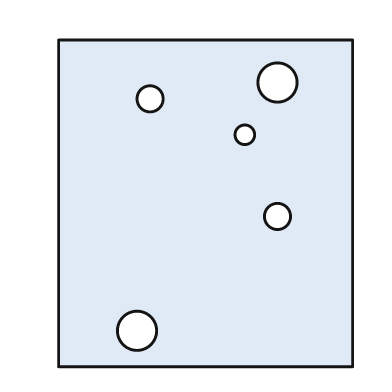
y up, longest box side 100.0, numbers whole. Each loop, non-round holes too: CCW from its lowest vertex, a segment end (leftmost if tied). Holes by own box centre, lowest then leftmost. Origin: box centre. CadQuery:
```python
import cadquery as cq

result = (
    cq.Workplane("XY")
    .moveTo(-45.0, -50.0)
    .lineTo(45.0, -50.0)
    .lineTo(45.0, 50.0)
    .lineTo(-45.0, 50.0)
    .close()
    .moveTo(-21.0, -39.0)
    .circle(6.0)
    .moveTo(22.0, -4.0)
    .circle(4.0)
    .moveTo(12.0, 21.0)
    .circle(3.0)
    .moveTo(-17.0, 32.0)
    .circle(4.0)
    .moveTo(22.0, 37.0)
    .circle(6.0)
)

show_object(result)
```